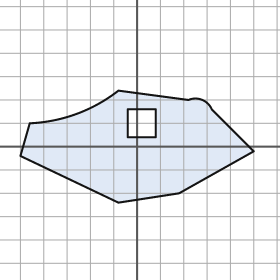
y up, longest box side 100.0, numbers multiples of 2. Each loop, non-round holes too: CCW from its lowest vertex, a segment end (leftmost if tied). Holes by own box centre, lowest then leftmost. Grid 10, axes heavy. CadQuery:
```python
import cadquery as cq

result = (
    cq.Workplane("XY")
    .moveTo(-8.0, -24.0)
    .lineTo(18.0, -20.0)
    .lineTo(50.0, -2.0)
    .lineTo(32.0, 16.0)
    .threePointArc((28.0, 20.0), (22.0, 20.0))
    .lineTo(-8.0, 24.0)
    .threePointArc((-26.0, 14.0), (-46.0, 10.0))
    .lineTo(-50.0, -4.0)
    .close()
    .moveTo(-4.0, 4.0)
    .lineTo(8.0, 4.0)
    .lineTo(8.0, 16.0)
    .lineTo(-4.0, 16.0)
    .close()
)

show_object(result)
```